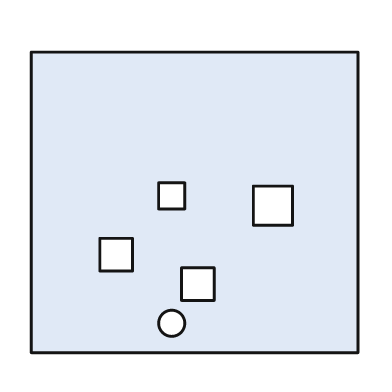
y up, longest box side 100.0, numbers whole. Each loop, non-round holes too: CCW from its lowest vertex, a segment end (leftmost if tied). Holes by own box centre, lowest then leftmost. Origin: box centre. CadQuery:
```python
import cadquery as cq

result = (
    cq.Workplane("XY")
    .moveTo(-50.0, -46.0)
    .lineTo(50.0, -46.0)
    .lineTo(50.0, 46.0)
    .lineTo(-50.0, 46.0)
    .close()
    .moveTo(-7.0, -37.0)
    .circle(4.0)
    .moveTo(-4.0, -30.0)
    .lineTo(6.0, -30.0)
    .lineTo(6.0, -20.0)
    .lineTo(-4.0, -20.0)
    .close()
    .moveTo(-29.0, -21.0)
    .lineTo(-19.0, -21.0)
    .lineTo(-19.0, -11.0)
    .lineTo(-29.0, -11.0)
    .close()
    .moveTo(18.0, -7.0)
    .lineTo(30.0, -7.0)
    .lineTo(30.0, 5.0)
    .lineTo(18.0, 5.0)
    .close()
    .moveTo(-11.0, -2.0)
    .lineTo(-3.0, -2.0)
    .lineTo(-3.0, 6.0)
    .lineTo(-11.0, 6.0)
    .close()
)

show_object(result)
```